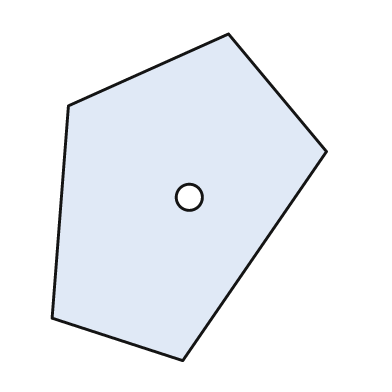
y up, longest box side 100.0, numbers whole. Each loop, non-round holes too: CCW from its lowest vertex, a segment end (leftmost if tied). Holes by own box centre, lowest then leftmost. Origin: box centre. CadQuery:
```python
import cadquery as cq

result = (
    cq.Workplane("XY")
    .moveTo(-2.0, -50.0)
    .lineTo(42.0, 14.0)
    .lineTo(12.0, 50.0)
    .lineTo(-37.0, 28.0)
    .lineTo(-42.0, -37.0)
    .close()
    .moveTo(0.0, 0.0)
    .circle(4.0)
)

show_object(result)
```